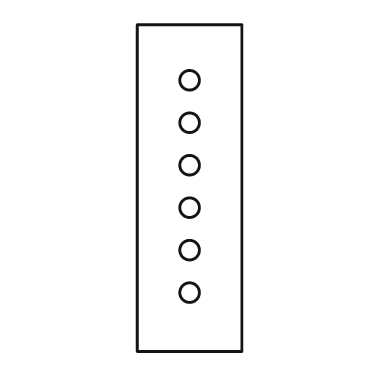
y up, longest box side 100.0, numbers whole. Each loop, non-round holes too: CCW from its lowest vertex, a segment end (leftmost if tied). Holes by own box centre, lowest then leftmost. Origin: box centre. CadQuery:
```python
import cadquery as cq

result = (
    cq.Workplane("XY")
    .moveTo(-16.0, -50.0)
    .lineTo(16.0, -50.0)
    .lineTo(16.0, 50.0)
    .lineTo(-16.0, 50.0)
    .close()
    .moveTo(0.0, -32.0)
    .circle(3.0)
    .moveTo(0.0, -19.0)
    .circle(3.0)
    .moveTo(0.0, -6.0)
    .circle(3.0)
    .moveTo(0.0, 7.0)
    .circle(3.0)
    .moveTo(0.0, 20.0)
    .circle(3.0)
    .moveTo(0.0, 33.0)
    .circle(3.0)
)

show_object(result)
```